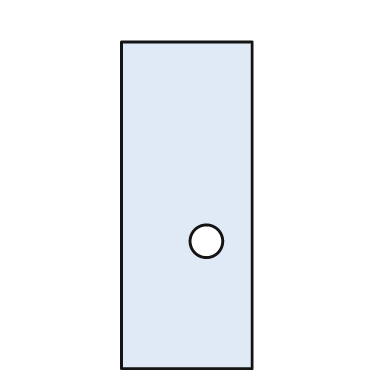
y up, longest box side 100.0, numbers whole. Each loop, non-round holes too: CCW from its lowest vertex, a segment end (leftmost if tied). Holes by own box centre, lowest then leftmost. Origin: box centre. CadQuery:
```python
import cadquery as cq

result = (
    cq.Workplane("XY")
    .moveTo(-20.0, -50.0)
    .lineTo(20.0, -50.0)
    .lineTo(20.0, 50.0)
    .lineTo(-20.0, 50.0)
    .close()
    .moveTo(6.0, -11.0)
    .circle(5.0)
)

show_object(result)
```